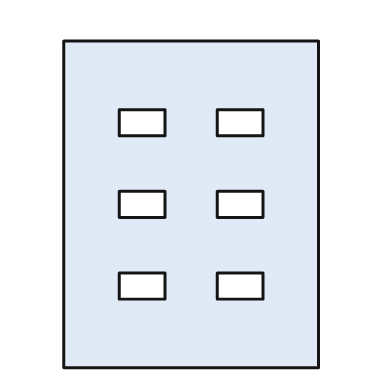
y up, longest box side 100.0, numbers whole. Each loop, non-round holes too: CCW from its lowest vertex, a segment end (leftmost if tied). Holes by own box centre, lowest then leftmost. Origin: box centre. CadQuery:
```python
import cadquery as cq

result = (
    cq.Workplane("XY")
    .moveTo(-39.0, -50.0)
    .lineTo(39.0, -50.0)
    .lineTo(39.0, 50.0)
    .lineTo(-39.0, 50.0)
    .close()
    .moveTo(-22.0, -29.0)
    .lineTo(-8.0, -29.0)
    .lineTo(-8.0, -21.0)
    .lineTo(-22.0, -21.0)
    .close()
    .moveTo(8.0, -29.0)
    .lineTo(22.0, -29.0)
    .lineTo(22.0, -21.0)
    .lineTo(8.0, -21.0)
    .close()
    .moveTo(-22.0, -4.0)
    .lineTo(-8.0, -4.0)
    .lineTo(-8.0, 4.0)
    .lineTo(-22.0, 4.0)
    .close()
    .moveTo(8.0, -4.0)
    .lineTo(22.0, -4.0)
    .lineTo(22.0, 4.0)
    .lineTo(8.0, 4.0)
    .close()
    .moveTo(-22.0, 21.0)
    .lineTo(-8.0, 21.0)
    .lineTo(-8.0, 29.0)
    .lineTo(-22.0, 29.0)
    .close()
    .moveTo(8.0, 21.0)
    .lineTo(22.0, 21.0)
    .lineTo(22.0, 29.0)
    .lineTo(8.0, 29.0)
    .close()
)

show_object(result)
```